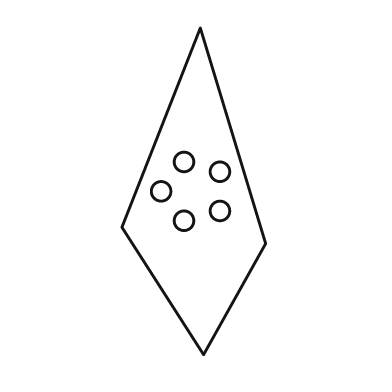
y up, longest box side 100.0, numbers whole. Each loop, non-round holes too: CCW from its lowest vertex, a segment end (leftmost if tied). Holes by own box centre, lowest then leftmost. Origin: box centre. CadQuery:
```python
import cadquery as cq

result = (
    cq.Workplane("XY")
    .moveTo(3.0, -50.0)
    .lineTo(22.0, -16.0)
    .lineTo(2.0, 50.0)
    .lineTo(-22.0, -11.0)
    .close()
    .moveTo(-3.0, -9.0)
    .circle(3.0)
    .moveTo(8.0, -6.0)
    .circle(3.0)
    .moveTo(-10.0, 0.0)
    .circle(3.0)
    .moveTo(8.0, 6.0)
    .circle(3.0)
    .moveTo(-3.0, 9.0)
    .circle(3.0)
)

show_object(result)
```